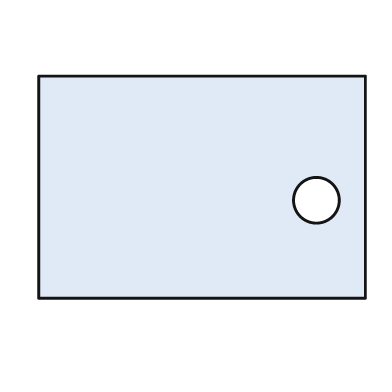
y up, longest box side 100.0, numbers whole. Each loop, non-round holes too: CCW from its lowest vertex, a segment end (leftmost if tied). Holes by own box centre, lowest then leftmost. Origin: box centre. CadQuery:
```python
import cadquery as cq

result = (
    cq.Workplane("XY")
    .moveTo(-50.0, -34.0)
    .lineTo(50.0, -34.0)
    .lineTo(50.0, 34.0)
    .lineTo(-50.0, 34.0)
    .close()
    .moveTo(35.0, -4.0)
    .circle(7.0)
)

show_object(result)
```